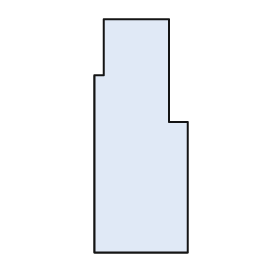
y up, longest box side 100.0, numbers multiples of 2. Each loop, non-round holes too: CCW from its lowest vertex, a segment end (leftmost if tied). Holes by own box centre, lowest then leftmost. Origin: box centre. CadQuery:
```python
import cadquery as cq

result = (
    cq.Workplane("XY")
    .moveTo(-20.0, -50.0)
    .lineTo(20.0, -50.0)
    .lineTo(20.0, 6.0)
    .lineTo(12.0, 6.0)
    .lineTo(12.0, 50.0)
    .lineTo(-16.0, 50.0)
    .lineTo(-16.0, 26.0)
    .lineTo(-20.0, 26.0)
    .close()
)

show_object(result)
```